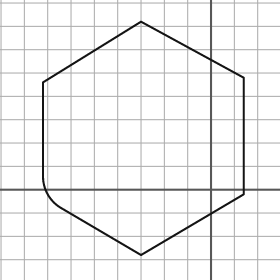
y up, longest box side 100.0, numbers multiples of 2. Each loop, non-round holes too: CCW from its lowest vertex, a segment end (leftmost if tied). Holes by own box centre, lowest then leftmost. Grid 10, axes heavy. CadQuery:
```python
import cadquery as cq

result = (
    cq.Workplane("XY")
    .moveTo(-30.0, -28.0)
    .lineTo(14.0, -2.0)
    .lineTo(14.0, 48.0)
    .lineTo(-30.0, 72.0)
    .lineTo(-72.0, 46.0)
    .lineTo(-72.0, 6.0)
    .threePointArc((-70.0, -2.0), (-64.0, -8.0))
    .close()
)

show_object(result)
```